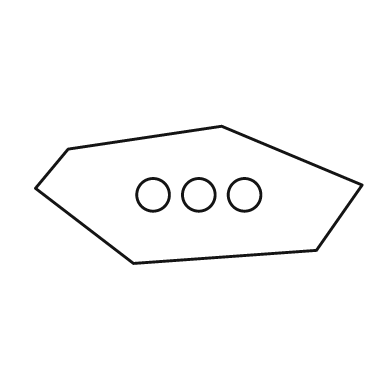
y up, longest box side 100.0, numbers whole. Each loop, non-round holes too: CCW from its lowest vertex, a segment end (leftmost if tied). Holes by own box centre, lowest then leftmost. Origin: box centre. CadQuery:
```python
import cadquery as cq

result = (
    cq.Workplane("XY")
    .moveTo(-20.0, -21.0)
    .lineTo(36.0, -17.0)
    .lineTo(50.0, 3.0)
    .lineTo(7.0, 21.0)
    .lineTo(-40.0, 14.0)
    .lineTo(-50.0, 2.0)
    .close()
    .moveTo(-14.0, 0.0)
    .circle(5.0)
    .moveTo(0.0, 0.0)
    .circle(5.0)
    .moveTo(14.0, 0.0)
    .circle(5.0)
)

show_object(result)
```